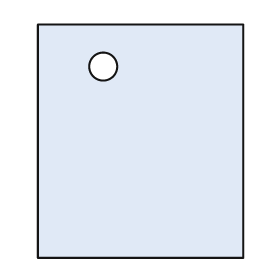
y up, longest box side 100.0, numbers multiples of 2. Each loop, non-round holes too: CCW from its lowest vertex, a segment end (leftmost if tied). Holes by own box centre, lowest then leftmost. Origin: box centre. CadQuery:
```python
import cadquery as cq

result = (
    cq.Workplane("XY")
    .moveTo(-44.0, -50.0)
    .lineTo(44.0, -50.0)
    .lineTo(44.0, 50.0)
    .lineTo(-44.0, 50.0)
    .close()
    .moveTo(-16.0, 32.0)
    .circle(6.0)
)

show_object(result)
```